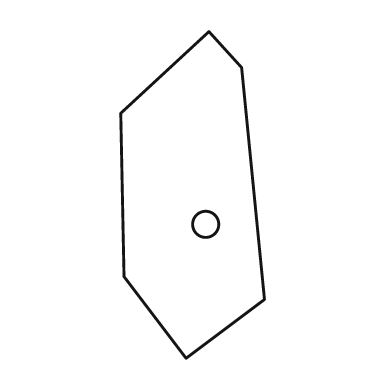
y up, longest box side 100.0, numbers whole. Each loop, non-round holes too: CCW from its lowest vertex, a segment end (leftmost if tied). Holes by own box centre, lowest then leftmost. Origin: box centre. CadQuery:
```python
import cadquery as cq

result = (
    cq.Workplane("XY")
    .moveTo(-2.0, -50.0)
    .lineTo(22.0, -32.0)
    .lineTo(15.0, 39.0)
    .lineTo(5.0, 50.0)
    .lineTo(-22.0, 25.0)
    .lineTo(-21.0, -25.0)
    .close()
    .moveTo(4.0, -9.0)
    .circle(4.0)
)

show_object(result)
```